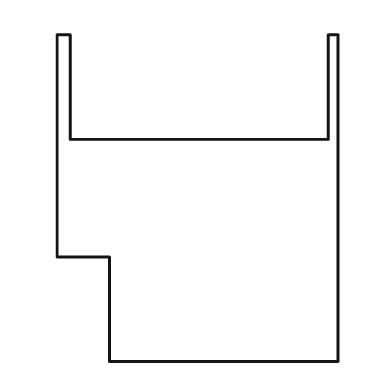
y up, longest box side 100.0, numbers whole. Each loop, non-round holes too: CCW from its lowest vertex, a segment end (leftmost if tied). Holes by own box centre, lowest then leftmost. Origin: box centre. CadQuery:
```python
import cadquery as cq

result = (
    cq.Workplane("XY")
    .moveTo(-27.0, -50.0)
    .lineTo(43.0, -50.0)
    .lineTo(43.0, 50.0)
    .lineTo(40.0, 50.0)
    .lineTo(40.0, 18.0)
    .lineTo(-39.0, 18.0)
    .lineTo(-39.0, 50.0)
    .lineTo(-43.0, 50.0)
    .lineTo(-43.0, -18.0)
    .lineTo(-27.0, -18.0)
    .close()
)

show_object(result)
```